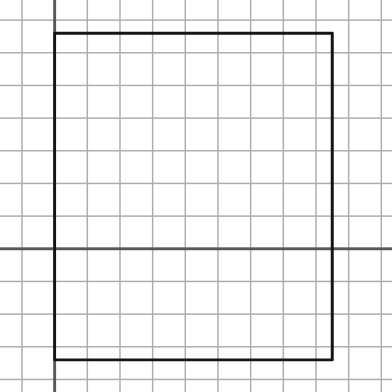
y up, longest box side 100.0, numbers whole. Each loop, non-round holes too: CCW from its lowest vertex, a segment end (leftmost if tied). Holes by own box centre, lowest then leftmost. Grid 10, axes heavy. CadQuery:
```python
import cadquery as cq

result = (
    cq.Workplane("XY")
    .moveTo(0.0, -34.0)
    .lineTo(85.0, -34.0)
    .lineTo(85.0, 66.0)
    .lineTo(0.0, 66.0)
    .close()
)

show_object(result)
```